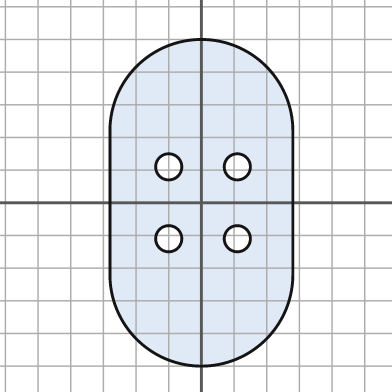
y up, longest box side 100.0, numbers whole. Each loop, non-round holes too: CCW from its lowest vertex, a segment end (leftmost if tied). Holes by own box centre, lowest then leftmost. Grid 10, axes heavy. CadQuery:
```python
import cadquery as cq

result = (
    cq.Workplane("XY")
    .moveTo(-28.0, -22.0)
    .threePointArc((0.0, -50.0), (28.0, -22.0))
    .lineTo(28.0, 22.0)
    .threePointArc((0.0, 50.0), (-28.0, 22.0))
    .close()
    .moveTo(-10.0, -11.0)
    .circle(4.0)
    .moveTo(11.0, -11.0)
    .circle(4.0)
    .moveTo(-10.0, 11.0)
    .circle(4.0)
    .moveTo(11.0, 11.0)
    .circle(4.0)
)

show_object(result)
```